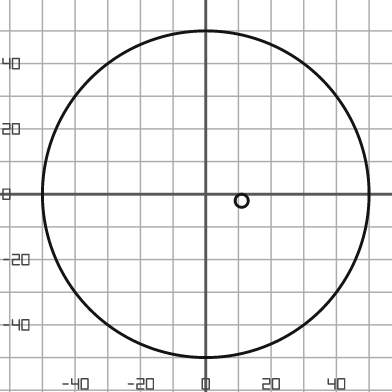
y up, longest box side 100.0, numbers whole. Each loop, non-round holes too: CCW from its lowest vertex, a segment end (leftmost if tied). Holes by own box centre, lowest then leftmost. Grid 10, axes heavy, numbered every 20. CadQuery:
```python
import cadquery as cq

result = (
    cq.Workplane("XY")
    .moveTo(0.0, 0.0)
    .circle(50.0)
    .moveTo(11.0, -2.0)
    .circle(2.0)
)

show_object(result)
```